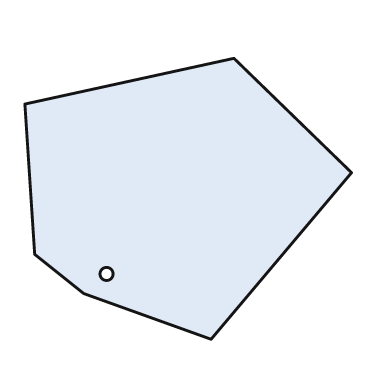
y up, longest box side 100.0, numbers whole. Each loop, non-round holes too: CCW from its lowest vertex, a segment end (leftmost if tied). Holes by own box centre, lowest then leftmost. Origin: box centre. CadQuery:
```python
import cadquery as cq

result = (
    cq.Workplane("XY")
    .moveTo(7.0, -43.0)
    .lineTo(50.0, 8.0)
    .lineTo(14.0, 43.0)
    .lineTo(-50.0, 29.0)
    .lineTo(-47.0, -17.0)
    .lineTo(-32.0, -29.0)
    .close()
    .moveTo(-25.0, -23.0)
    .circle(2.0)
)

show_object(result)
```